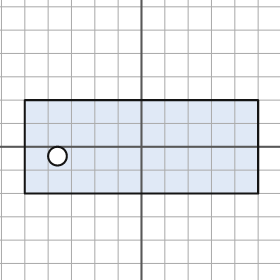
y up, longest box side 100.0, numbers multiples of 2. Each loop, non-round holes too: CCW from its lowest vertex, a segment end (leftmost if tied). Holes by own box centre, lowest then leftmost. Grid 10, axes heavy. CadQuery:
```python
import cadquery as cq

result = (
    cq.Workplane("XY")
    .moveTo(-50.0, -20.0)
    .lineTo(50.0, -20.0)
    .lineTo(50.0, 20.0)
    .lineTo(-50.0, 20.0)
    .close()
    .moveTo(-36.0, -4.0)
    .circle(4.0)
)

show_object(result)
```